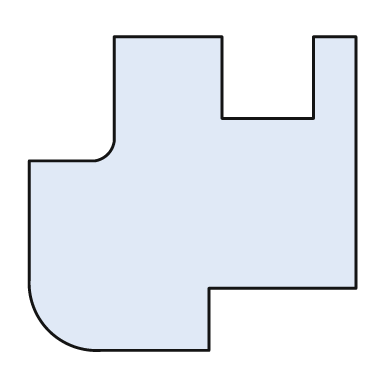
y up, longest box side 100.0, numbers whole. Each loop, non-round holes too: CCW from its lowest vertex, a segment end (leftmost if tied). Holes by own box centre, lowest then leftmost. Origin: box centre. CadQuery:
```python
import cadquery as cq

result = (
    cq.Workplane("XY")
    .moveTo(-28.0, -48.0)
    .lineTo(5.0, -48.0)
    .lineTo(5.0, -29.0)
    .lineTo(50.0, -29.0)
    .lineTo(50.0, 48.0)
    .lineTo(37.0, 48.0)
    .lineTo(37.0, 23.0)
    .lineTo(9.0, 23.0)
    .lineTo(9.0, 48.0)
    .lineTo(-24.0, 48.0)
    .lineTo(-24.0, 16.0)
    .threePointArc((-26.0, 12.0), (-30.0, 10.0))
    .lineTo(-50.0, 10.0)
    .lineTo(-50.0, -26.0)
    .threePointArc((-44.0, -42.0), (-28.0, -48.0))
    .close()
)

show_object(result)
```